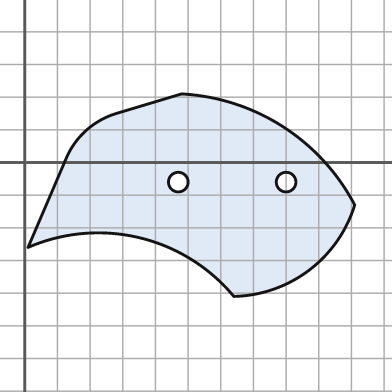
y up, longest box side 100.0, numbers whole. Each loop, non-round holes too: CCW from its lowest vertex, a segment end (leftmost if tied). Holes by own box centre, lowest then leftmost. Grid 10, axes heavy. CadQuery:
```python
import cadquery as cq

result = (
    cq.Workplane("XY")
    .moveTo(64.0, -41.0)
    .threePointArc((87.0, -33.0), (101.0, -13.0))
    .threePointArc((79.0, 11.0), (48.0, 21.0))
    .lineTo(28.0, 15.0)
    .threePointArc((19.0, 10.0), (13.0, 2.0))
    .lineTo(1.0, -26.0)
    .threePointArc((35.0, -23.0), (64.0, -41.0))
    .close()
    .moveTo(47.0, -6.0)
    .circle(3.0)
    .moveTo(80.0, -6.0)
    .circle(3.0)
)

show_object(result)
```